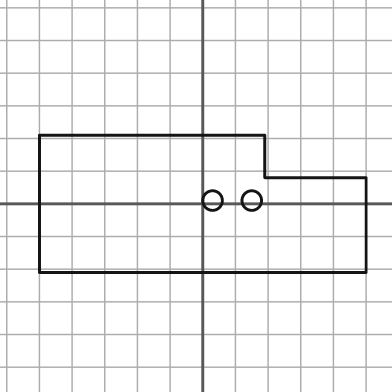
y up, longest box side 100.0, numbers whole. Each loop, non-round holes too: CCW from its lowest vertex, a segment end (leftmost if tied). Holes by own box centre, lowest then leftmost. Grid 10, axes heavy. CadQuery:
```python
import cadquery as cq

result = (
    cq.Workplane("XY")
    .moveTo(-50.0, -21.0)
    .lineTo(50.0, -21.0)
    .lineTo(50.0, 8.0)
    .lineTo(19.0, 8.0)
    .lineTo(19.0, 21.0)
    .lineTo(-50.0, 21.0)
    .close()
    .moveTo(3.0, 1.0)
    .circle(3.0)
    .moveTo(15.0, 1.0)
    .circle(3.0)
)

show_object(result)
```